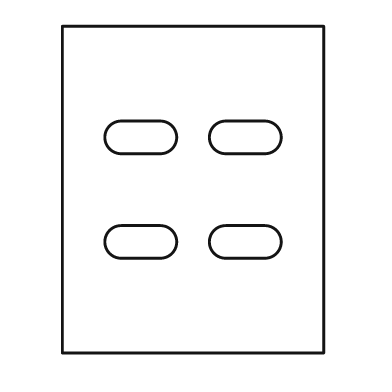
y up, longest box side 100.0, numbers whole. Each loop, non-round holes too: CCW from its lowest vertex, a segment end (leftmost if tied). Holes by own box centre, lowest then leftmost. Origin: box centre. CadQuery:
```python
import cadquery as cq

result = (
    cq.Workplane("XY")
    .moveTo(-40.0, -50.0)
    .lineTo(40.0, -50.0)
    .lineTo(40.0, 50.0)
    .lineTo(-40.0, 50.0)
    .close()
    .moveTo(-22.0, -21.0)
    .lineTo(-10.0, -21.0)
    .threePointArc((-5.0, -16.0), (-10.0, -11.0))
    .lineTo(-22.0, -11.0)
    .threePointArc((-27.0, -16.0), (-22.0, -21.0))
    .close()
    .moveTo(10.0, -21.0)
    .lineTo(22.0, -21.0)
    .threePointArc((27.0, -16.0), (22.0, -11.0))
    .lineTo(10.0, -11.0)
    .threePointArc((5.0, -16.0), (10.0, -21.0))
    .close()
    .moveTo(-22.0, 11.0)
    .lineTo(-10.0, 11.0)
    .threePointArc((-5.0, 16.0), (-10.0, 21.0))
    .lineTo(-22.0, 21.0)
    .threePointArc((-27.0, 16.0), (-22.0, 11.0))
    .close()
    .moveTo(10.0, 11.0)
    .lineTo(22.0, 11.0)
    .threePointArc((27.0, 16.0), (22.0, 21.0))
    .lineTo(10.0, 21.0)
    .threePointArc((5.0, 16.0), (10.0, 11.0))
    .close()
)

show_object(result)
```